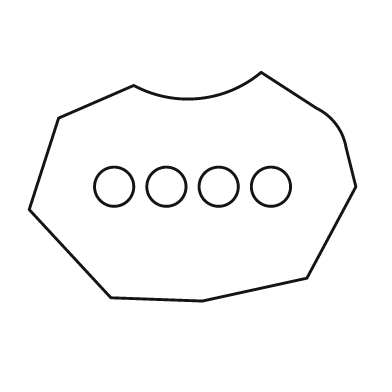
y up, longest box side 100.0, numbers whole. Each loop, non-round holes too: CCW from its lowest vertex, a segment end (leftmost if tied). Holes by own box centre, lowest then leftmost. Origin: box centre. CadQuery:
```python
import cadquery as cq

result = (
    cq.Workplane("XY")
    .moveTo(3.0, -35.0)
    .lineTo(35.0, -28.0)
    .lineTo(50.0, 0.0)
    .lineTo(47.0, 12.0)
    .threePointArc((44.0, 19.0), (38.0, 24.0))
    .lineTo(21.0, 35.0)
    .threePointArc((2.0, 27.0), (-18.0, 31.0))
    .lineTo(-41.0, 21.0)
    .lineTo(-50.0, -7.0)
    .lineTo(-25.0, -34.0)
    .close()
    .moveTo(-24.0, 0.0)
    .circle(6.0)
    .moveTo(-8.0, 0.0)
    .circle(6.0)
    .moveTo(8.0, 0.0)
    .circle(6.0)
    .moveTo(24.0, 0.0)
    .circle(6.0)
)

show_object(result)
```